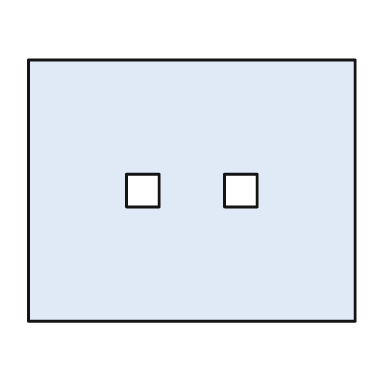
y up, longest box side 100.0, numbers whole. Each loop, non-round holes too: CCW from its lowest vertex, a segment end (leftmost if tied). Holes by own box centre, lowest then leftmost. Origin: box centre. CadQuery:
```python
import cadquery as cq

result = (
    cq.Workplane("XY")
    .moveTo(-50.0, -40.0)
    .lineTo(50.0, -40.0)
    .lineTo(50.0, 40.0)
    .lineTo(-50.0, 40.0)
    .close()
    .moveTo(-20.0, -5.0)
    .lineTo(-10.0, -5.0)
    .lineTo(-10.0, 5.0)
    .lineTo(-20.0, 5.0)
    .close()
    .moveTo(10.0, -5.0)
    .lineTo(20.0, -5.0)
    .lineTo(20.0, 5.0)
    .lineTo(10.0, 5.0)
    .close()
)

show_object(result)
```